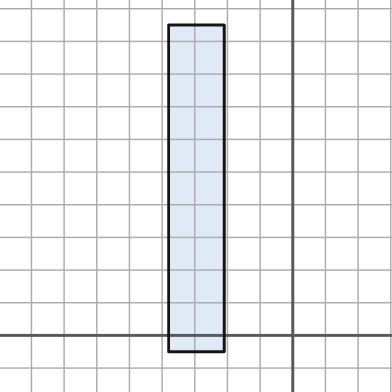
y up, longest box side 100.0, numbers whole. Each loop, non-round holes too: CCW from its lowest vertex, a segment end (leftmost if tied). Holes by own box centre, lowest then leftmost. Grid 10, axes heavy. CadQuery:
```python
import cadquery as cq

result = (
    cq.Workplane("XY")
    .moveTo(-38.0, -5.0)
    .lineTo(-21.0, -5.0)
    .lineTo(-21.0, 95.0)
    .lineTo(-38.0, 95.0)
    .close()
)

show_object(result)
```